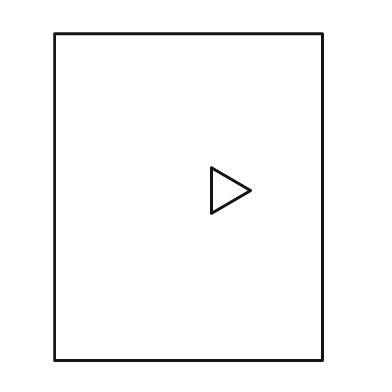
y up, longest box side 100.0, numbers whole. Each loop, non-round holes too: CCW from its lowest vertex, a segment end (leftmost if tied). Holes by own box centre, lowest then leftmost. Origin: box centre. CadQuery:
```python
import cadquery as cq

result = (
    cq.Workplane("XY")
    .moveTo(-41.0, -50.0)
    .lineTo(41.0, -50.0)
    .lineTo(41.0, 50.0)
    .lineTo(-41.0, 50.0)
    .close()
    .moveTo(7.0, -5.0)
    .lineTo(19.0, 2.0)
    .lineTo(7.0, 9.0)
    .close()
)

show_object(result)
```